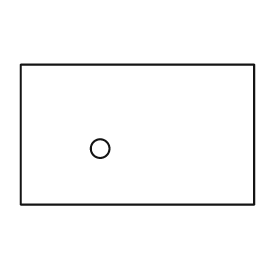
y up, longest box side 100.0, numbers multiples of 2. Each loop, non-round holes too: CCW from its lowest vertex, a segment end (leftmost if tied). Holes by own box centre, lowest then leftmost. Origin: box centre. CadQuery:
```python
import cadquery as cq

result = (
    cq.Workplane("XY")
    .moveTo(-50.0, -30.0)
    .lineTo(50.0, -30.0)
    .lineTo(50.0, 30.0)
    .lineTo(-50.0, 30.0)
    .close()
    .moveTo(-16.0, -6.0)
    .circle(4.0)
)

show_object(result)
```